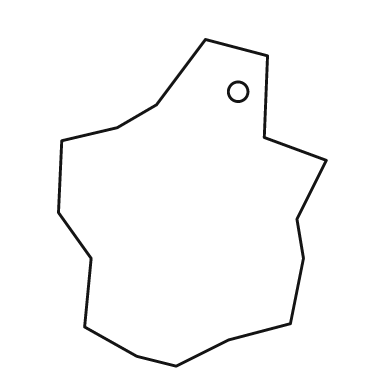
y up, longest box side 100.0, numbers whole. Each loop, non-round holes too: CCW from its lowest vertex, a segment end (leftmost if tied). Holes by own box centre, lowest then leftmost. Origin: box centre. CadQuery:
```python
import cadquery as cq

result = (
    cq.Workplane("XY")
    .moveTo(-5.0, -50.0)
    .lineTo(11.0, -42.0)
    .lineTo(30.0, -37.0)
    .lineTo(34.0, -17.0)
    .lineTo(32.0, -5.0)
    .lineTo(41.0, 13.0)
    .lineTo(22.0, 20.0)
    .lineTo(23.0, 45.0)
    .lineTo(4.0, 50.0)
    .lineTo(-11.0, 30.0)
    .lineTo(-23.0, 23.0)
    .lineTo(-40.0, 19.0)
    .lineTo(-41.0, -3.0)
    .lineTo(-31.0, -17.0)
    .lineTo(-33.0, -38.0)
    .lineTo(-17.0, -47.0)
    .close()
    .moveTo(14.0, 34.0)
    .circle(3.0)
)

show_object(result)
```